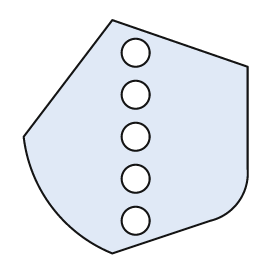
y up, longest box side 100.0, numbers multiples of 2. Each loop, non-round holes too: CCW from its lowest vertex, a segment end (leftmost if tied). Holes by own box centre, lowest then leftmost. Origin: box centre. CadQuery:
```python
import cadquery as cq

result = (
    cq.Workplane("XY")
    .moveTo(-10.0, -50.0)
    .lineTo(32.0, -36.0)
    .threePointArc((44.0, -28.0), (48.0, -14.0))
    .lineTo(48.0, 30.0)
    .lineTo(-10.0, 50.0)
    .lineTo(-48.0, 0.0)
    .threePointArc((-36.0, -30.0), (-10.0, -50.0))
    .close()
    .moveTo(0.0, -36.0)
    .circle(6.0)
    .moveTo(0.0, -18.0)
    .circle(6.0)
    .moveTo(0.0, 0.0)
    .circle(6.0)
    .moveTo(0.0, 18.0)
    .circle(6.0)
    .moveTo(0.0, 36.0)
    .circle(6.0)
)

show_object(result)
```